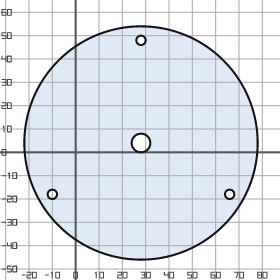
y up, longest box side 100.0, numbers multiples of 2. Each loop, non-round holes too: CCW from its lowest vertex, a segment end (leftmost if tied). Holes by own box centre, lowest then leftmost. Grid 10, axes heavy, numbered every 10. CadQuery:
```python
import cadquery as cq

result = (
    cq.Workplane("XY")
    .moveTo(28.0, 4.0)
    .circle(50.0)
    .moveTo(-10.0, -18.0)
    .circle(2.0)
    .moveTo(66.0, -18.0)
    .circle(2.0)
    .moveTo(28.0, 4.0)
    .circle(4.0)
    .moveTo(28.0, 48.0)
    .circle(2.0)
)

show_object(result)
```